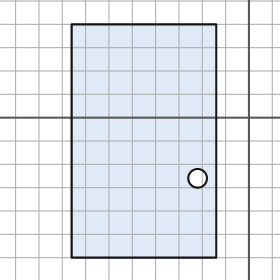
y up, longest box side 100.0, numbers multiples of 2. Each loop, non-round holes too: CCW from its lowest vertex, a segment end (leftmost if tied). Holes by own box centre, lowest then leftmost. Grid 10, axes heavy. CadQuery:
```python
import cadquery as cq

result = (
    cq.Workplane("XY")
    .moveTo(-76.0, -60.0)
    .lineTo(-14.0, -60.0)
    .lineTo(-14.0, 40.0)
    .lineTo(-76.0, 40.0)
    .close()
    .moveTo(-22.0, -26.0)
    .circle(4.0)
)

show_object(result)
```